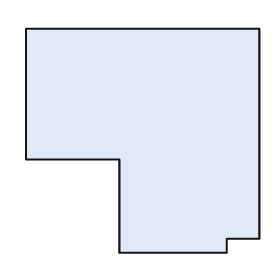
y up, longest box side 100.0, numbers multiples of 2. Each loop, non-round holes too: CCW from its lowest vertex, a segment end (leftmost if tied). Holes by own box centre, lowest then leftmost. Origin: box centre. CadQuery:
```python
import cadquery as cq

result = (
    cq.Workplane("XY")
    .moveTo(-10.0, -48.0)
    .lineTo(36.0, -48.0)
    .lineTo(36.0, -42.0)
    .lineTo(50.0, -42.0)
    .lineTo(50.0, 48.0)
    .lineTo(-50.0, 48.0)
    .lineTo(-50.0, -8.0)
    .lineTo(-10.0, -8.0)
    .close()
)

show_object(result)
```